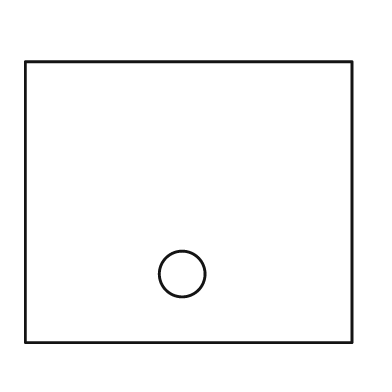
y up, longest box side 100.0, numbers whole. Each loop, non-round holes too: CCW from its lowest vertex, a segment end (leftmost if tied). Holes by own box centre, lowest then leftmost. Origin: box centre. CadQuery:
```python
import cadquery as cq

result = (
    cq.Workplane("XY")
    .moveTo(-50.0, -43.0)
    .lineTo(50.0, -43.0)
    .lineTo(50.0, 43.0)
    .lineTo(-50.0, 43.0)
    .close()
    .moveTo(-2.0, -22.0)
    .circle(7.0)
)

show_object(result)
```